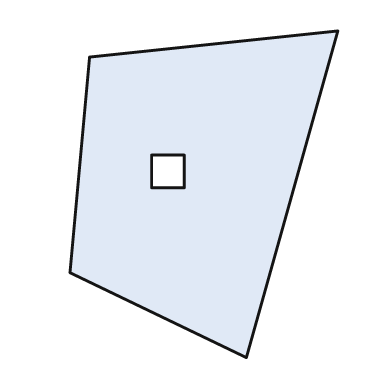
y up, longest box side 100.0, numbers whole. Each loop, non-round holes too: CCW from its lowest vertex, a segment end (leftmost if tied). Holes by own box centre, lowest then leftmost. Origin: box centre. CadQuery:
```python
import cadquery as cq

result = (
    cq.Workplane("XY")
    .moveTo(13.0, -50.0)
    .lineTo(41.0, 50.0)
    .lineTo(-35.0, 42.0)
    .lineTo(-41.0, -24.0)
    .close()
    .moveTo(-16.0, 2.0)
    .lineTo(-6.0, 2.0)
    .lineTo(-6.0, 12.0)
    .lineTo(-16.0, 12.0)
    .close()
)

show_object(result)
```